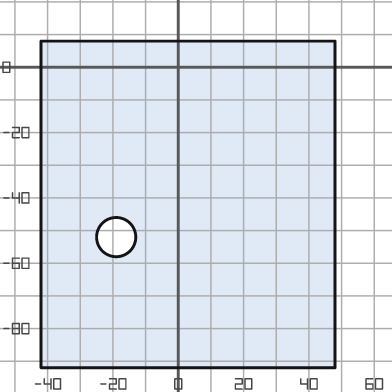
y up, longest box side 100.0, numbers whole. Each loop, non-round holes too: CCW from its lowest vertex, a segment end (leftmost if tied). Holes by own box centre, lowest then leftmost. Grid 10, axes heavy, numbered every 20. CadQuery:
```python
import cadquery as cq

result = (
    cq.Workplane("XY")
    .moveTo(-42.0, -92.0)
    .lineTo(48.0, -92.0)
    .lineTo(48.0, 8.0)
    .lineTo(-42.0, 8.0)
    .close()
    .moveTo(-19.0, -52.0)
    .circle(6.0)
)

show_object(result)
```